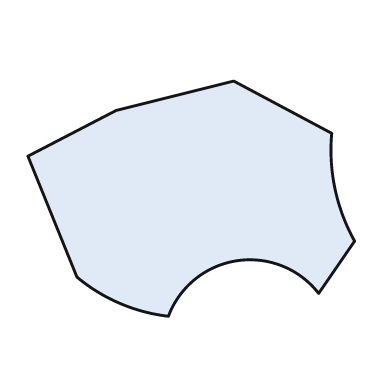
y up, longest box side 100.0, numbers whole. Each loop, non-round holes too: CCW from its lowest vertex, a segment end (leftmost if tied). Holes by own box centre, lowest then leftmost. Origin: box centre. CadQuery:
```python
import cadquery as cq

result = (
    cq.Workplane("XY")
    .moveTo(-7.0, -36.0)
    .threePointArc((14.0, -19.0), (39.0, -29.0))
    .lineTo(50.0, -13.0)
    .threePointArc((44.0, 3.0), (43.0, 20.0))
    .lineTo(13.0, 36.0)
    .lineTo(-23.0, 27.0)
    .lineTo(-50.0, 13.0)
    .lineTo(-35.0, -24.0)
    .threePointArc((-22.0, -32.0), (-7.0, -36.0))
    .close()
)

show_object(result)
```